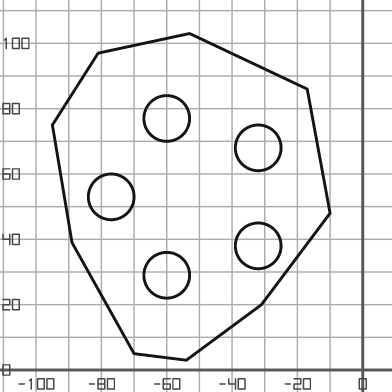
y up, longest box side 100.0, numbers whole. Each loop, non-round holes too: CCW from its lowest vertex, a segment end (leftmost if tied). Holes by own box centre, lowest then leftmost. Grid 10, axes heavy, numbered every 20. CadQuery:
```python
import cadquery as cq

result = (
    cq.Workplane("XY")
    .moveTo(-54.0, 3.0)
    .lineTo(-31.0, 20.0)
    .lineTo(-10.0, 48.0)
    .lineTo(-17.0, 86.0)
    .lineTo(-53.0, 103.0)
    .lineTo(-81.0, 97.0)
    .lineTo(-95.0, 75.0)
    .lineTo(-89.0, 39.0)
    .lineTo(-70.0, 5.0)
    .close()
    .moveTo(-60.0, 29.0)
    .circle(7.0)
    .moveTo(-32.0, 38.0)
    .circle(7.0)
    .moveTo(-77.0, 53.0)
    .circle(7.0)
    .moveTo(-32.0, 68.0)
    .circle(7.0)
    .moveTo(-60.0, 77.0)
    .circle(7.0)
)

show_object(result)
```